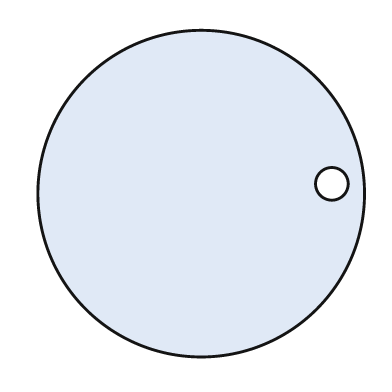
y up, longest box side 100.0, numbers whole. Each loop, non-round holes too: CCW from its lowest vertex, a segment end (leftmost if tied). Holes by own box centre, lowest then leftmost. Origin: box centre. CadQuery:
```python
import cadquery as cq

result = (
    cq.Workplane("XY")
    .moveTo(0.0, 0.0)
    .circle(50.0)
    .moveTo(40.0, 3.0)
    .circle(5.0)
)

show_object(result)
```